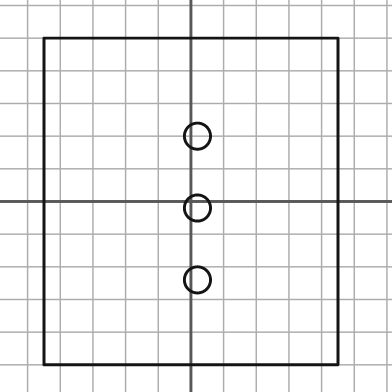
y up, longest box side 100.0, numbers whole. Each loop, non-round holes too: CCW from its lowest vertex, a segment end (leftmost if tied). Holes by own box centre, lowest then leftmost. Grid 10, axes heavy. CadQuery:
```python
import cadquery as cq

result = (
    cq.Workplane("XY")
    .moveTo(-45.0, -50.0)
    .lineTo(45.0, -50.0)
    .lineTo(45.0, 50.0)
    .lineTo(-45.0, 50.0)
    .close()
    .moveTo(2.0, -24.0)
    .circle(4.0)
    .moveTo(2.0, -2.0)
    .circle(4.0)
    .moveTo(2.0, 20.0)
    .circle(4.0)
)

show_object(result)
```